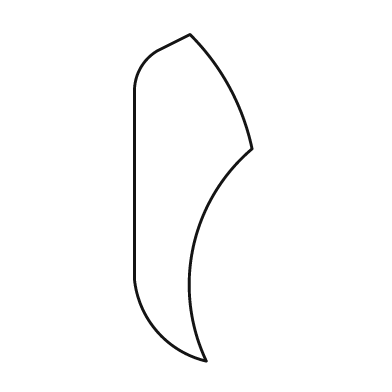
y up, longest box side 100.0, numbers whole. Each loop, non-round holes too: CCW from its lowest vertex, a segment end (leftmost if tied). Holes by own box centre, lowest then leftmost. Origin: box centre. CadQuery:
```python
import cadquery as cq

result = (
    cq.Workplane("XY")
    .moveTo(4.0, -50.0)
    .threePointArc((0.0, -15.0), (18.0, 15.0))
    .threePointArc((11.0, 34.0), (-1.0, 50.0))
    .lineTo(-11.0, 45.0)
    .threePointArc((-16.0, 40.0), (-18.0, 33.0))
    .lineTo(-18.0, -25.0)
    .threePointArc((-11.0, -41.0), (4.0, -50.0))
    .close()
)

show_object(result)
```